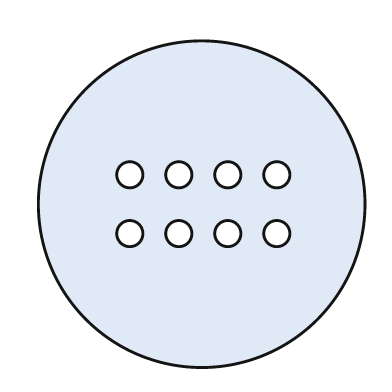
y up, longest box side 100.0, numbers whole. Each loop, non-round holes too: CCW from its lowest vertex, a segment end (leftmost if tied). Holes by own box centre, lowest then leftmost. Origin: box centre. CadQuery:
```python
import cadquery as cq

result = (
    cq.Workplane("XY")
    .moveTo(0.0, 0.0)
    .circle(50.0)
    .moveTo(-22.0, -9.0)
    .circle(4.0)
    .moveTo(-7.0, -9.0)
    .circle(4.0)
    .moveTo(8.0, -9.0)
    .circle(4.0)
    .moveTo(23.0, -9.0)
    .circle(4.0)
    .moveTo(-22.0, 9.0)
    .circle(4.0)
    .moveTo(-7.0, 9.0)
    .circle(4.0)
    .moveTo(8.0, 9.0)
    .circle(4.0)
    .moveTo(23.0, 9.0)
    .circle(4.0)
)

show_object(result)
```